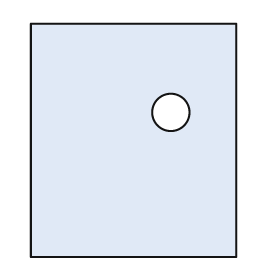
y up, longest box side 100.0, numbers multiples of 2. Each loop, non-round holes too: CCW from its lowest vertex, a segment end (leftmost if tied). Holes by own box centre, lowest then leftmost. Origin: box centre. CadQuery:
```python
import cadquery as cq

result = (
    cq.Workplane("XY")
    .moveTo(-44.0, -50.0)
    .lineTo(44.0, -50.0)
    .lineTo(44.0, 50.0)
    .lineTo(-44.0, 50.0)
    .close()
    .moveTo(16.0, 12.0)
    .circle(8.0)
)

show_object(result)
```